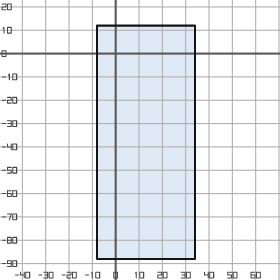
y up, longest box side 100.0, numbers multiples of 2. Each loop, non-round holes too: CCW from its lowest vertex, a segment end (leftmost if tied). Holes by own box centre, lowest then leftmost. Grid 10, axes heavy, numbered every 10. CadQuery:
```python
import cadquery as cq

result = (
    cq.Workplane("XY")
    .moveTo(-8.0, -88.0)
    .lineTo(34.0, -88.0)
    .lineTo(34.0, 12.0)
    .lineTo(-8.0, 12.0)
    .close()
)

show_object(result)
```